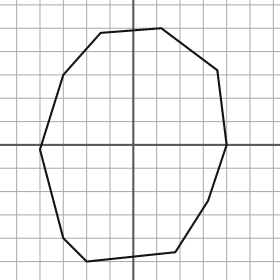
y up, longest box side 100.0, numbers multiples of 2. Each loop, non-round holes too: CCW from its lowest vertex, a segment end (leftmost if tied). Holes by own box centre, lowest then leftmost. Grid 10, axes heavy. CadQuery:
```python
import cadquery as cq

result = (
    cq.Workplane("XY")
    .moveTo(-20.0, -50.0)
    .lineTo(18.0, -46.0)
    .lineTo(32.0, -24.0)
    .lineTo(40.0, 0.0)
    .lineTo(36.0, 32.0)
    .lineTo(12.0, 50.0)
    .lineTo(-14.0, 48.0)
    .lineTo(-30.0, 30.0)
    .lineTo(-40.0, -2.0)
    .lineTo(-30.0, -40.0)
    .close()
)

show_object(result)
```